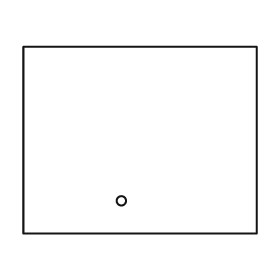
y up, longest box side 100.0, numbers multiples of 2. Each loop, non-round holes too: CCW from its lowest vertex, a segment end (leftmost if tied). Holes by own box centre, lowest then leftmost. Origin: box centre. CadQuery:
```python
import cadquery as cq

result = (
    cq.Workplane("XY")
    .moveTo(-50.0, -40.0)
    .lineTo(50.0, -40.0)
    .lineTo(50.0, 40.0)
    .lineTo(-50.0, 40.0)
    .close()
    .moveTo(-8.0, -26.0)
    .circle(2.0)
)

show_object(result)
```